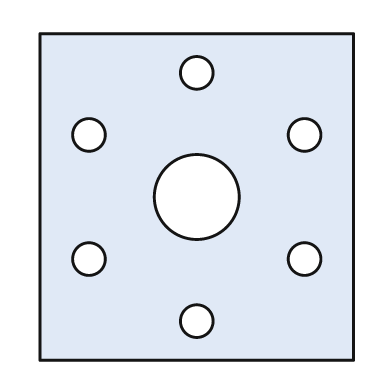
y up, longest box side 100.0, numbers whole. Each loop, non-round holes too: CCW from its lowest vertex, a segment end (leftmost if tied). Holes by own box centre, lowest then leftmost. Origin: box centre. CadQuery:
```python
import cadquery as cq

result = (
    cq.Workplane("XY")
    .moveTo(-48.0, -50.0)
    .lineTo(48.0, -50.0)
    .lineTo(48.0, 50.0)
    .lineTo(-48.0, 50.0)
    .close()
    .moveTo(0.0, -38.0)
    .circle(5.0)
    .moveTo(-33.0, -19.0)
    .circle(5.0)
    .moveTo(33.0, -19.0)
    .circle(5.0)
    .moveTo(0.0, 0.0)
    .circle(13.0)
    .moveTo(-33.0, 19.0)
    .circle(5.0)
    .moveTo(33.0, 19.0)
    .circle(5.0)
    .moveTo(0.0, 38.0)
    .circle(5.0)
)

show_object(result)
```